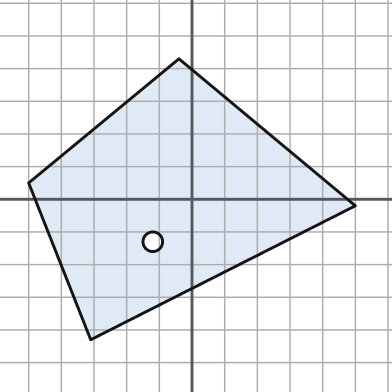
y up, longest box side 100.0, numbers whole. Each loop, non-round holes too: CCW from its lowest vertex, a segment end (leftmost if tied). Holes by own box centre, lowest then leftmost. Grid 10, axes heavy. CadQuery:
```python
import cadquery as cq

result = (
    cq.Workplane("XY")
    .moveTo(-31.0, -43.0)
    .lineTo(50.0, -2.0)
    .lineTo(-4.0, 43.0)
    .lineTo(-50.0, 5.0)
    .close()
    .moveTo(-12.0, -13.0)
    .circle(3.0)
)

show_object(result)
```